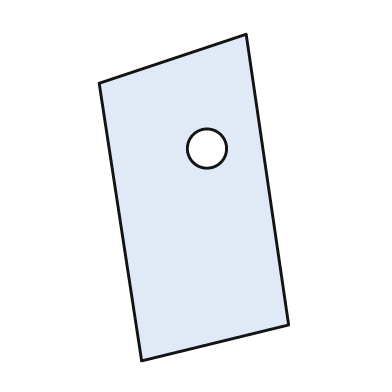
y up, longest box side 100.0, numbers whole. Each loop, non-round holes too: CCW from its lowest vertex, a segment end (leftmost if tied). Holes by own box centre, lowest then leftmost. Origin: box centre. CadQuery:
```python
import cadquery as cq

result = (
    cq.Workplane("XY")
    .moveTo(-16.0, -50.0)
    .lineTo(29.0, -39.0)
    .lineTo(16.0, 50.0)
    .lineTo(-29.0, 35.0)
    .close()
    .moveTo(4.0, 15.0)
    .circle(6.0)
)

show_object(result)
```